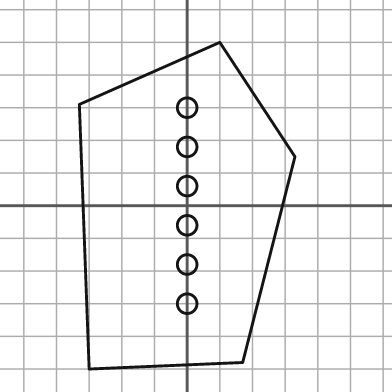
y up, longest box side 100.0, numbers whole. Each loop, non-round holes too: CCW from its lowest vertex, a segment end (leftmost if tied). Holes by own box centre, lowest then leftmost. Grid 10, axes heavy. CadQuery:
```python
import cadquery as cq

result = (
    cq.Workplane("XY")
    .moveTo(-30.0, -50.0)
    .lineTo(17.0, -48.0)
    .lineTo(33.0, 15.0)
    .lineTo(10.0, 50.0)
    .lineTo(-33.0, 31.0)
    .close()
    .moveTo(0.0, -30.0)
    .circle(3.0)
    .moveTo(0.0, -18.0)
    .circle(3.0)
    .moveTo(0.0, -6.0)
    .circle(3.0)
    .moveTo(0.0, 6.0)
    .circle(3.0)
    .moveTo(0.0, 18.0)
    .circle(3.0)
    .moveTo(0.0, 30.0)
    .circle(3.0)
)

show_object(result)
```